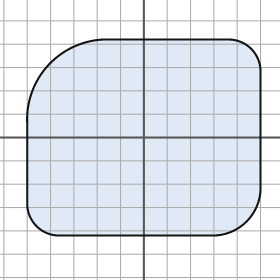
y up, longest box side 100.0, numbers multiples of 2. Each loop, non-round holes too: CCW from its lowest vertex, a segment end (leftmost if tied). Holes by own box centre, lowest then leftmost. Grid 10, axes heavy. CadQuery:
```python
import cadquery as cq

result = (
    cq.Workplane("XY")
    .moveTo(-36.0, -42.0)
    .lineTo(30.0, -42.0)
    .threePointArc((44.0, -36.0), (50.0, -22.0))
    .lineTo(50.0, 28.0)
    .threePointArc((46.0, 38.0), (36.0, 42.0))
    .lineTo(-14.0, 42.0)
    .threePointArc((-40.0, 32.0), (-50.0, 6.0))
    .lineTo(-50.0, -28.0)
    .threePointArc((-46.0, -38.0), (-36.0, -42.0))
    .close()
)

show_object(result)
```